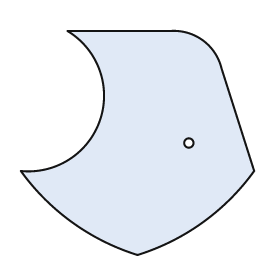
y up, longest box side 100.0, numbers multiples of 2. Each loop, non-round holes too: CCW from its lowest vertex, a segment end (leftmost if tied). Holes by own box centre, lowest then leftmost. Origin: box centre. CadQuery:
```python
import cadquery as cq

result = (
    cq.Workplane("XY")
    .moveTo(0.0, -48.0)
    .threePointArc((28.0, -34.0), (50.0, -12.0))
    .lineTo(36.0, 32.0)
    .threePointArc((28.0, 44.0), (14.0, 48.0))
    .lineTo(-30.0, 48.0)
    .threePointArc((-16.0, 10.0), (-50.0, -12.0))
    .threePointArc((-28.0, -34.0), (0.0, -48.0))
    .close()
    .moveTo(22.0, 0.0)
    .circle(2.0)
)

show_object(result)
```